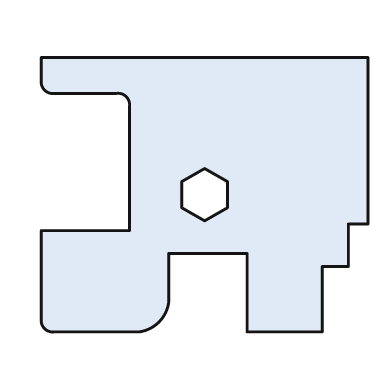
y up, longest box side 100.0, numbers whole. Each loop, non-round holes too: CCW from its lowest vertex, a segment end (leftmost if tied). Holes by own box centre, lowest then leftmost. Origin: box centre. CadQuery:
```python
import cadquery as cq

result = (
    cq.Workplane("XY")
    .moveTo(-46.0, -42.0)
    .lineTo(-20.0, -42.0)
    .threePointArc((-14.0, -39.0), (-11.0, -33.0))
    .lineTo(-11.0, -18.0)
    .lineTo(13.0, -18.0)
    .lineTo(13.0, -42.0)
    .lineTo(36.0, -42.0)
    .lineTo(36.0, -22.0)
    .lineTo(44.0, -22.0)
    .lineTo(44.0, -9.0)
    .lineTo(50.0, -9.0)
    .lineTo(50.0, 42.0)
    .lineTo(-50.0, 42.0)
    .lineTo(-50.0, 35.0)
    .threePointArc((-49.0, 32.0), (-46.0, 31.0))
    .lineTo(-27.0, 31.0)
    .threePointArc((-24.0, 30.0), (-23.0, 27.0))
    .lineTo(-23.0, -11.0)
    .lineTo(-50.0, -11.0)
    .lineTo(-50.0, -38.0)
    .threePointArc((-49.0, -41.0), (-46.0, -42.0))
    .close()
    .moveTo(0.0, -8.0)
    .lineTo(7.0, -4.0)
    .lineTo(7.0, 4.0)
    .lineTo(0.0, 8.0)
    .lineTo(-7.0, 4.0)
    .lineTo(-7.0, -4.0)
    .close()
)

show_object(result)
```